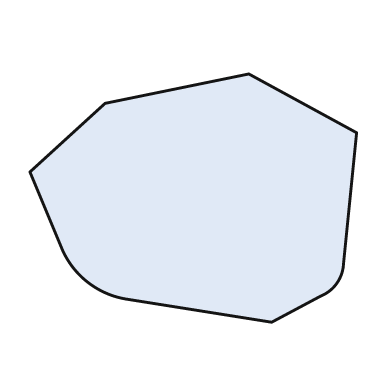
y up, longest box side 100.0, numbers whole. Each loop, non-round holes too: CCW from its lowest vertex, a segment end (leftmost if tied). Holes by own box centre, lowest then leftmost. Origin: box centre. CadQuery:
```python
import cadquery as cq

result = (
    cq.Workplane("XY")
    .moveTo(24.0, -38.0)
    .lineTo(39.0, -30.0)
    .threePointArc((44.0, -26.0), (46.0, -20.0))
    .lineTo(50.0, 20.0)
    .lineTo(17.0, 38.0)
    .lineTo(-27.0, 29.0)
    .lineTo(-50.0, 8.0)
    .lineTo(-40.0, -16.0)
    .threePointArc((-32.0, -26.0), (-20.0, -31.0))
    .close()
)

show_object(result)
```